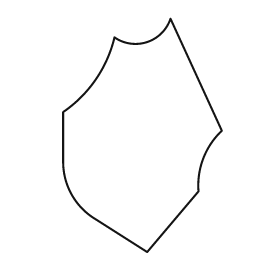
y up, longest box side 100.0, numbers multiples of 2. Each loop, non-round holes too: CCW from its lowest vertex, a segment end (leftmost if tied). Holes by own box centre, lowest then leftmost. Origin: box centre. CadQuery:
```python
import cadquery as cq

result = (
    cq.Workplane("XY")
    .moveTo(2.0, -50.0)
    .lineTo(24.0, -24.0)
    .threePointArc((26.0, -10.0), (34.0, 2.0))
    .lineTo(12.0, 50.0)
    .threePointArc((2.0, 40.0), (-12.0, 42.0))
    .threePointArc((-20.0, 24.0), (-34.0, 10.0))
    .lineTo(-34.0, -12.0)
    .threePointArc((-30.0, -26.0), (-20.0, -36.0))
    .close()
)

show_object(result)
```